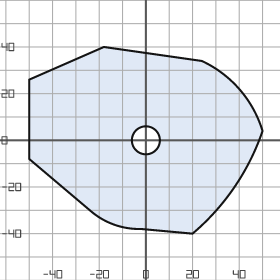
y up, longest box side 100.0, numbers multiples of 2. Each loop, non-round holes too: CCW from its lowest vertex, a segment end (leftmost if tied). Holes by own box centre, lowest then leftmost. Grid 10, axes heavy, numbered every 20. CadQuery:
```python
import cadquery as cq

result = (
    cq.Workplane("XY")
    .moveTo(20.0, -40.0)
    .threePointArc((38.0, -20.0), (50.0, 4.0))
    .threePointArc((40.0, 22.0), (24.0, 34.0))
    .lineTo(-18.0, 40.0)
    .lineTo(-50.0, 26.0)
    .lineTo(-50.0, -8.0)
    .lineTo(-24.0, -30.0)
    .threePointArc((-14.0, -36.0), (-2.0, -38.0))
    .close()
    .moveTo(0.0, 0.0)
    .circle(6.0)
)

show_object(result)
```